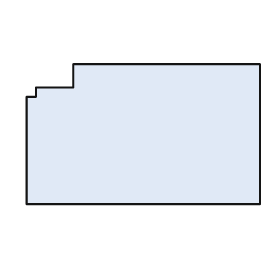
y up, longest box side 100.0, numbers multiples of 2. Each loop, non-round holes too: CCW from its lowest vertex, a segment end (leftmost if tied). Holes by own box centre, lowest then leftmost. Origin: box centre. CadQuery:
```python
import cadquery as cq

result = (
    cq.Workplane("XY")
    .moveTo(-50.0, -30.0)
    .lineTo(50.0, -30.0)
    .lineTo(50.0, 30.0)
    .lineTo(-30.0, 30.0)
    .lineTo(-30.0, 20.0)
    .lineTo(-46.0, 20.0)
    .lineTo(-46.0, 16.0)
    .lineTo(-50.0, 16.0)
    .close()
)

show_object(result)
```